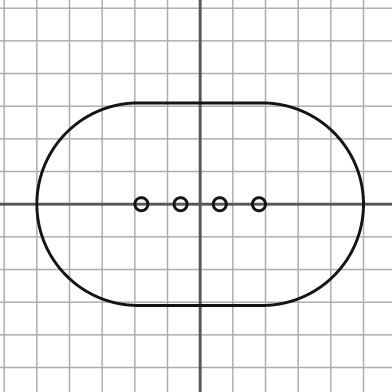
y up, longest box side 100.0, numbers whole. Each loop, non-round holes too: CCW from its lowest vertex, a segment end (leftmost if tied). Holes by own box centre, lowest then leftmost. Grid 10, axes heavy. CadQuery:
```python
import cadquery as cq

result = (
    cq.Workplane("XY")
    .moveTo(-19.0, -31.0)
    .lineTo(19.0, -31.0)
    .threePointArc((50.0, 0.0), (19.0, 31.0))
    .lineTo(-19.0, 31.0)
    .threePointArc((-50.0, 0.0), (-19.0, -31.0))
    .close()
    .moveTo(-18.0, 0.0)
    .circle(2.0)
    .moveTo(-6.0, 0.0)
    .circle(2.0)
    .moveTo(6.0, 0.0)
    .circle(2.0)
    .moveTo(18.0, 0.0)
    .circle(2.0)
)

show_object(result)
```